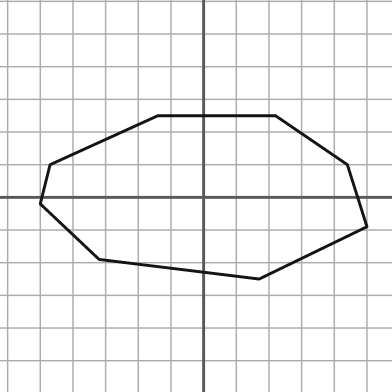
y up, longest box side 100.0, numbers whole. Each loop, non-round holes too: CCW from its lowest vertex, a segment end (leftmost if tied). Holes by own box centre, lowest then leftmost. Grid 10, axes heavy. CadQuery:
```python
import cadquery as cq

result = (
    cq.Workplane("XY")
    .moveTo(17.0, -25.0)
    .lineTo(50.0, -9.0)
    .lineTo(44.0, 10.0)
    .lineTo(22.0, 25.0)
    .lineTo(-14.0, 25.0)
    .lineTo(-47.0, 10.0)
    .lineTo(-50.0, -2.0)
    .lineTo(-32.0, -19.0)
    .close()
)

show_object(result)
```